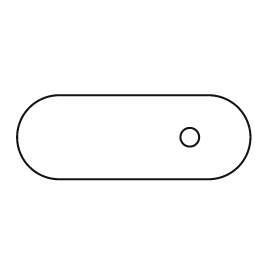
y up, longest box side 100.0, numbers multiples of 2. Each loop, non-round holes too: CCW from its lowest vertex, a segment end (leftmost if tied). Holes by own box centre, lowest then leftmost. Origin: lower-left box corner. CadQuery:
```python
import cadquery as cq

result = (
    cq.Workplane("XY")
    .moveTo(18.0, 0.0)
    .lineTo(82.0, 0.0)
    .threePointArc((100.0, 18.0), (82.0, 36.0))
    .lineTo(18.0, 36.0)
    .threePointArc((0.0, 18.0), (18.0, 0.0))
    .close()
    .moveTo(74.0, 18.0)
    .circle(4.0)
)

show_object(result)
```